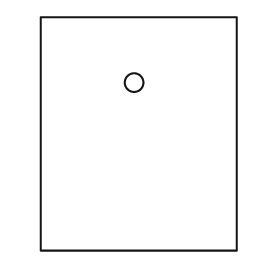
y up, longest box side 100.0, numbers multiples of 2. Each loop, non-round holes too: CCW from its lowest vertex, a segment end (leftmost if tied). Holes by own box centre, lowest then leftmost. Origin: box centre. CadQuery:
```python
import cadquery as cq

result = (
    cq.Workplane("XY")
    .moveTo(-42.0, -50.0)
    .lineTo(42.0, -50.0)
    .lineTo(42.0, 50.0)
    .lineTo(-42.0, 50.0)
    .close()
    .moveTo(-2.0, 22.0)
    .circle(4.0)
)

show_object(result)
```